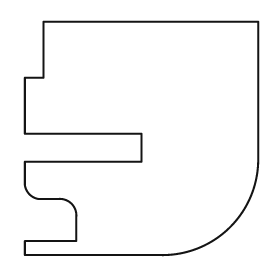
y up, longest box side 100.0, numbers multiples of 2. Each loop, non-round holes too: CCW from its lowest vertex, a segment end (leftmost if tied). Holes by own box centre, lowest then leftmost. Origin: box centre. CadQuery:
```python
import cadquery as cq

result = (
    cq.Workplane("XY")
    .moveTo(-50.0, -50.0)
    .lineTo(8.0, -50.0)
    .threePointArc((38.0, -38.0), (50.0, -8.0))
    .lineTo(50.0, 50.0)
    .lineTo(-42.0, 50.0)
    .lineTo(-42.0, 26.0)
    .lineTo(-50.0, 26.0)
    .lineTo(-50.0, 2.0)
    .lineTo(0.0, 2.0)
    .lineTo(0.0, -10.0)
    .lineTo(-50.0, -10.0)
    .lineTo(-50.0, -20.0)
    .threePointArc((-48.0, -24.0), (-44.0, -26.0))
    .lineTo(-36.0, -26.0)
    .threePointArc((-30.0, -28.0), (-28.0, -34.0))
    .lineTo(-28.0, -44.0)
    .lineTo(-50.0, -44.0)
    .close()
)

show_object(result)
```